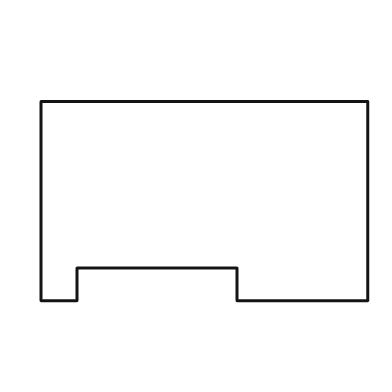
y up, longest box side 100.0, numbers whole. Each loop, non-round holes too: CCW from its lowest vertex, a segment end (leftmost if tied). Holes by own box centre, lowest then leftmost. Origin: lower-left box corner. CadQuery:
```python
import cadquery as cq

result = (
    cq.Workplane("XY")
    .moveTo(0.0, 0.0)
    .lineTo(11.0, 0.0)
    .lineTo(11.0, 10.0)
    .lineTo(60.0, 10.0)
    .lineTo(60.0, 0.0)
    .lineTo(100.0, 0.0)
    .lineTo(100.0, 61.0)
    .lineTo(0.0, 61.0)
    .close()
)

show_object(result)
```